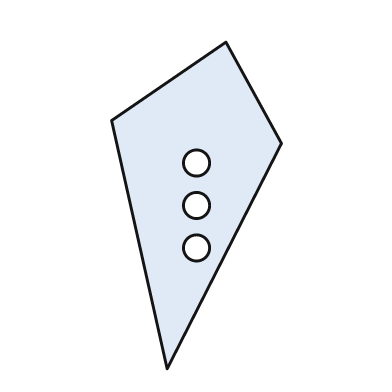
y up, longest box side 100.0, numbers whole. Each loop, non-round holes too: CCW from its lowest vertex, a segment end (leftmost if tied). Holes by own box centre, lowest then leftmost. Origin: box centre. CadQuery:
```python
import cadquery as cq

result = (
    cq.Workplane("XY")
    .moveTo(-9.0, -50.0)
    .lineTo(26.0, 19.0)
    .lineTo(9.0, 50.0)
    .lineTo(-26.0, 26.0)
    .close()
    .moveTo(0.0, -13.0)
    .circle(4.0)
    .moveTo(0.0, 0.0)
    .circle(4.0)
    .moveTo(0.0, 13.0)
    .circle(4.0)
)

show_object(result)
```